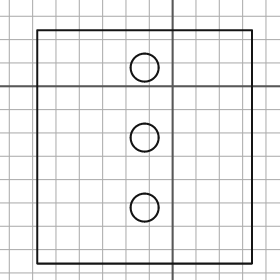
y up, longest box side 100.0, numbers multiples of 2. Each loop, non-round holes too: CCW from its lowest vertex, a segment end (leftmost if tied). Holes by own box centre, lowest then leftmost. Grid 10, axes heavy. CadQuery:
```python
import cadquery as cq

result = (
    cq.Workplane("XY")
    .moveTo(-58.0, -76.0)
    .lineTo(34.0, -76.0)
    .lineTo(34.0, 24.0)
    .lineTo(-58.0, 24.0)
    .close()
    .moveTo(-12.0, -52.0)
    .circle(6.0)
    .moveTo(-12.0, -22.0)
    .circle(6.0)
    .moveTo(-12.0, 8.0)
    .circle(6.0)
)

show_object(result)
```